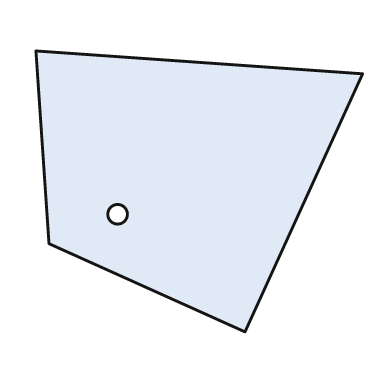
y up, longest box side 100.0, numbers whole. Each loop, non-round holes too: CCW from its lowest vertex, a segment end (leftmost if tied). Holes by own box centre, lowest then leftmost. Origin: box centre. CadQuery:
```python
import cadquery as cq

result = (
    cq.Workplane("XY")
    .moveTo(14.0, -43.0)
    .lineTo(50.0, 36.0)
    .lineTo(-50.0, 43.0)
    .lineTo(-46.0, -16.0)
    .close()
    .moveTo(-25.0, -7.0)
    .circle(3.0)
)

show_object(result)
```